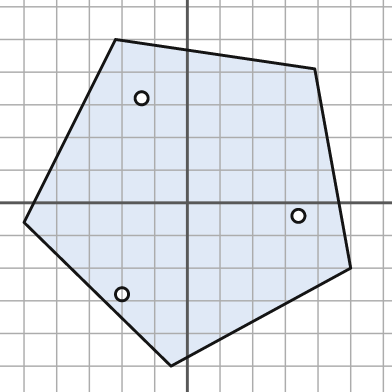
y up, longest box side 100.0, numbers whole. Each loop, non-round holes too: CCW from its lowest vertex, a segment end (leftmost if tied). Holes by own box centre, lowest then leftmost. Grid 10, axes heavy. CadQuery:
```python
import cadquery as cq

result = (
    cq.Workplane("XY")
    .moveTo(-5.0, -50.0)
    .lineTo(50.0, -20.0)
    .lineTo(39.0, 41.0)
    .lineTo(-22.0, 50.0)
    .lineTo(-50.0, -6.0)
    .close()
    .moveTo(-20.0, -28.0)
    .circle(2.0)
    .moveTo(34.0, -4.0)
    .circle(2.0)
    .moveTo(-14.0, 32.0)
    .circle(2.0)
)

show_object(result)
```